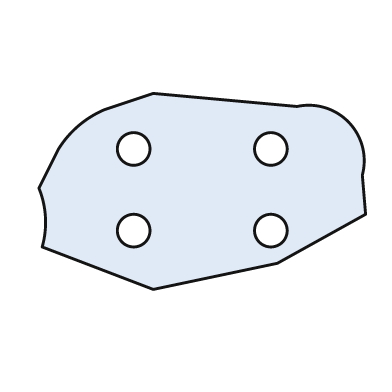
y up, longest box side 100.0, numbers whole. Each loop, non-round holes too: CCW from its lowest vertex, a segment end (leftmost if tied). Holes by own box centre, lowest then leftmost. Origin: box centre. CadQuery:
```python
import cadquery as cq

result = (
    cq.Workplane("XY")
    .moveTo(-15.0, -30.0)
    .lineTo(23.0, -22.0)
    .lineTo(50.0, -7.0)
    .lineTo(49.0, 5.0)
    .threePointArc((45.0, 21.0), (29.0, 26.0))
    .lineTo(-15.0, 30.0)
    .lineTo(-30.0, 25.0)
    .threePointArc((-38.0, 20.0), (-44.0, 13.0))
    .lineTo(-50.0, 1.0)
    .threePointArc((-48.0, -8.0), (-49.0, -17.0))
    .close()
    .moveTo(-21.0, -12.0)
    .circle(5.0)
    .moveTo(21.0, -12.0)
    .circle(5.0)
    .moveTo(-21.0, 13.0)
    .circle(5.0)
    .moveTo(21.0, 13.0)
    .circle(5.0)
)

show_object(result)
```